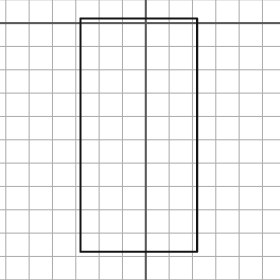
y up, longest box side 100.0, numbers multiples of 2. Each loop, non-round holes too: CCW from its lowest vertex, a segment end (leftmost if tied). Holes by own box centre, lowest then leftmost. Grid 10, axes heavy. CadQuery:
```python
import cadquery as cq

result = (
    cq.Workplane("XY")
    .moveTo(-28.0, -98.0)
    .lineTo(22.0, -98.0)
    .lineTo(22.0, 2.0)
    .lineTo(-28.0, 2.0)
    .close()
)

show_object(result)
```